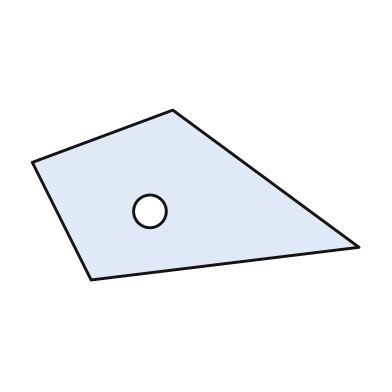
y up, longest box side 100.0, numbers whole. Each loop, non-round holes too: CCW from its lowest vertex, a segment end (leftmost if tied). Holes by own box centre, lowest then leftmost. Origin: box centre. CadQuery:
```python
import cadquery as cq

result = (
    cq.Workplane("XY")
    .moveTo(-32.0, -26.0)
    .lineTo(50.0, -16.0)
    .lineTo(-7.0, 26.0)
    .lineTo(-50.0, 10.0)
    .close()
    .moveTo(-14.0, -5.0)
    .circle(5.0)
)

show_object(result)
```